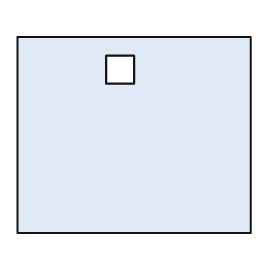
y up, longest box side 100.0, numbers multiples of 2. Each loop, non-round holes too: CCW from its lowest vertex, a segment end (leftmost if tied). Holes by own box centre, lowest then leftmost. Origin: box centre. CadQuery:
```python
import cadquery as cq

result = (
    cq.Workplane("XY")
    .moveTo(-50.0, -42.0)
    .lineTo(50.0, -42.0)
    .lineTo(50.0, 42.0)
    .lineTo(-50.0, 42.0)
    .close()
    .moveTo(-12.0, 22.0)
    .lineTo(0.0, 22.0)
    .lineTo(0.0, 34.0)
    .lineTo(-12.0, 34.0)
    .close()
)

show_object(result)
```